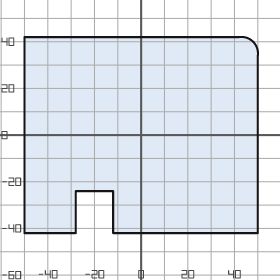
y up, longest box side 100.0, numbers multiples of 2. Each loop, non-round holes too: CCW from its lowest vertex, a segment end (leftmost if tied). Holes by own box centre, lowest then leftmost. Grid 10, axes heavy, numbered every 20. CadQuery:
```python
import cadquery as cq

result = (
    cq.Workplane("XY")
    .moveTo(-50.0, -42.0)
    .lineTo(-28.0, -42.0)
    .lineTo(-28.0, -24.0)
    .lineTo(-12.0, -24.0)
    .lineTo(-12.0, -42.0)
    .lineTo(50.0, -42.0)
    .lineTo(50.0, 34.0)
    .threePointArc((48.0, 40.0), (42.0, 42.0))
    .lineTo(-50.0, 42.0)
    .close()
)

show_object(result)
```